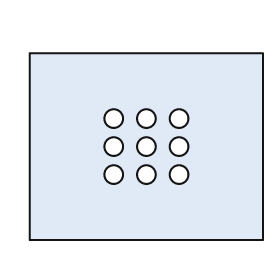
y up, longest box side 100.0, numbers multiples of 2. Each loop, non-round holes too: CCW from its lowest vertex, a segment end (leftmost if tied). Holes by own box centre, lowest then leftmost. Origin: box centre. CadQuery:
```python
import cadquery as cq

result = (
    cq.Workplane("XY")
    .moveTo(-50.0, -40.0)
    .lineTo(50.0, -40.0)
    .lineTo(50.0, 40.0)
    .lineTo(-50.0, 40.0)
    .close()
    .moveTo(-14.0, -12.0)
    .circle(4.0)
    .moveTo(0.0, -12.0)
    .circle(4.0)
    .moveTo(14.0, -12.0)
    .circle(4.0)
    .moveTo(-14.0, 0.0)
    .circle(4.0)
    .moveTo(0.0, 0.0)
    .circle(4.0)
    .moveTo(14.0, 0.0)
    .circle(4.0)
    .moveTo(-14.0, 12.0)
    .circle(4.0)
    .moveTo(0.0, 12.0)
    .circle(4.0)
    .moveTo(14.0, 12.0)
    .circle(4.0)
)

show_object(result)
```